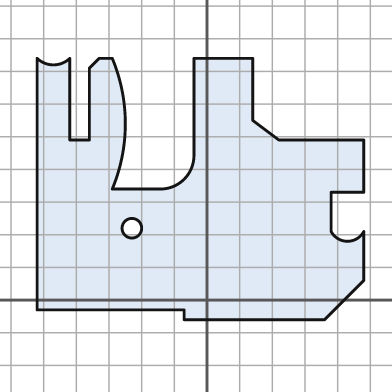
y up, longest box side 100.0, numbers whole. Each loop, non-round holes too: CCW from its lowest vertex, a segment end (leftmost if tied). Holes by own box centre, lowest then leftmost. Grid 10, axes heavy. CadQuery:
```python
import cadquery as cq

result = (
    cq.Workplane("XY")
    .moveTo(-7.0, -6.0)
    .lineTo(36.0, -6.0)
    .lineTo(48.0, 6.0)
    .lineTo(48.0, 21.0)
    .threePointArc((43.0, 18.0), (38.0, 21.0))
    .lineTo(38.0, 33.0)
    .lineTo(48.0, 33.0)
    .lineTo(48.0, 49.0)
    .lineTo(22.0, 49.0)
    .lineTo(14.0, 55.0)
    .lineTo(14.0, 74.0)
    .lineTo(-4.0, 74.0)
    .lineTo(-4.0, 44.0)
    .threePointArc((-7.0, 37.0), (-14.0, 34.0))
    .lineTo(-29.0, 34.0)
    .threePointArc((-25.0, 54.0), (-29.0, 74.0))
    .lineTo(-33.0, 74.0)
    .lineTo(-36.0, 71.0)
    .lineTo(-36.0, 49.0)
    .lineTo(-42.0, 49.0)
    .lineTo(-42.0, 74.0)
    .threePointArc((-47.0, 72.0), (-52.0, 74.0))
    .lineTo(-52.0, -3.0)
    .lineTo(-7.0, -3.0)
    .close()
    .moveTo(-23.0, 22.0)
    .circle(3.0)
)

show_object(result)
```